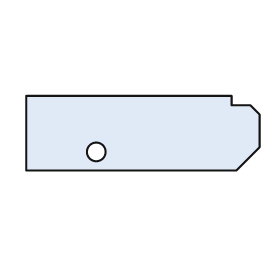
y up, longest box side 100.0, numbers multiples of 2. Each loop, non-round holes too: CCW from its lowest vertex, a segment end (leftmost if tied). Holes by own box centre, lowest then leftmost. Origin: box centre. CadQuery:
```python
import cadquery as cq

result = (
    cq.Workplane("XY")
    .moveTo(-50.0, -16.0)
    .lineTo(40.0, -16.0)
    .lineTo(50.0, -6.0)
    .lineTo(50.0, 8.0)
    .lineTo(46.0, 12.0)
    .lineTo(38.0, 12.0)
    .lineTo(38.0, 16.0)
    .lineTo(-50.0, 16.0)
    .close()
    .moveTo(-20.0, -8.0)
    .circle(4.0)
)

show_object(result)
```